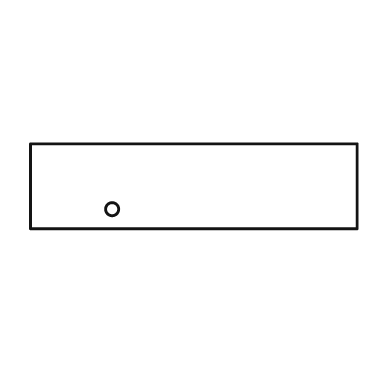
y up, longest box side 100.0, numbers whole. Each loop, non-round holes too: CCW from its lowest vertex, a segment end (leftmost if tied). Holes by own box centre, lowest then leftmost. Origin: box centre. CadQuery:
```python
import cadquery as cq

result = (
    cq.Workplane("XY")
    .moveTo(-50.0, -13.0)
    .lineTo(50.0, -13.0)
    .lineTo(50.0, 13.0)
    .lineTo(-50.0, 13.0)
    .close()
    .moveTo(-25.0, -7.0)
    .circle(2.0)
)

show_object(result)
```